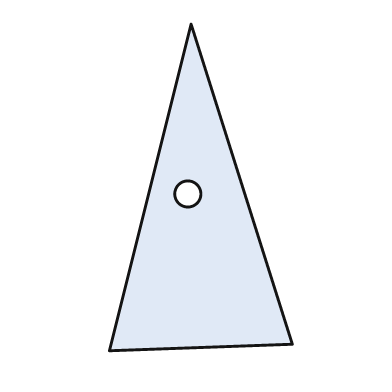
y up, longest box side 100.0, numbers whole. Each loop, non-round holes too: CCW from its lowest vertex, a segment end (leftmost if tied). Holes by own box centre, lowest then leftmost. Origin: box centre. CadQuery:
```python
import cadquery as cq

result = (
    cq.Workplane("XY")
    .moveTo(-28.0, -50.0)
    .lineTo(28.0, -48.0)
    .lineTo(-3.0, 50.0)
    .close()
    .moveTo(-4.0, -2.0)
    .circle(4.0)
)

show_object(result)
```